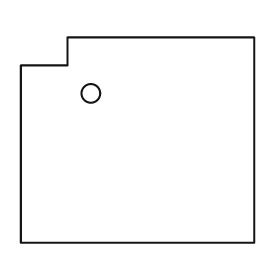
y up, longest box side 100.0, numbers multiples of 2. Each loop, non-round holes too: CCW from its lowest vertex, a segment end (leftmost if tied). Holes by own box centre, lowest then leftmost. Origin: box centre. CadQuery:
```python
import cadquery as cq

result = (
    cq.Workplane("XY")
    .moveTo(-50.0, -44.0)
    .lineTo(50.0, -44.0)
    .lineTo(50.0, 44.0)
    .lineTo(-30.0, 44.0)
    .lineTo(-30.0, 32.0)
    .lineTo(-50.0, 32.0)
    .close()
    .moveTo(-20.0, 20.0)
    .circle(4.0)
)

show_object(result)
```